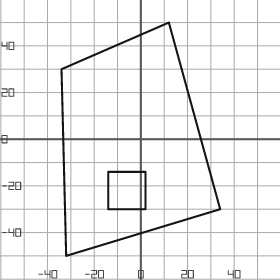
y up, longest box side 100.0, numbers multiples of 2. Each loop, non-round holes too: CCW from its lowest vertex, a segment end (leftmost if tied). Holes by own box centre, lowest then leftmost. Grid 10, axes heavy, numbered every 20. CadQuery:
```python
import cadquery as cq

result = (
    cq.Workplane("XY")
    .moveTo(-32.0, -50.0)
    .lineTo(34.0, -30.0)
    .lineTo(12.0, 50.0)
    .lineTo(-34.0, 30.0)
    .close()
    .moveTo(-14.0, -30.0)
    .lineTo(2.0, -30.0)
    .lineTo(2.0, -14.0)
    .lineTo(-14.0, -14.0)
    .close()
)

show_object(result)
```